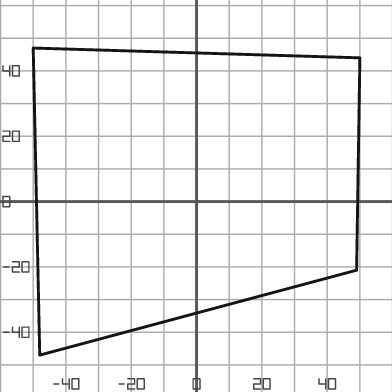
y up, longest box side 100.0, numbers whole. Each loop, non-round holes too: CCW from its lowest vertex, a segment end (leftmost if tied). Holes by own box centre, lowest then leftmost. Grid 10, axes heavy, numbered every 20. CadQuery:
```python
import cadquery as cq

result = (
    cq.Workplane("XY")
    .moveTo(-48.0, -47.0)
    .lineTo(49.0, -21.0)
    .lineTo(50.0, 44.0)
    .lineTo(-50.0, 47.0)
    .close()
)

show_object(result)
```